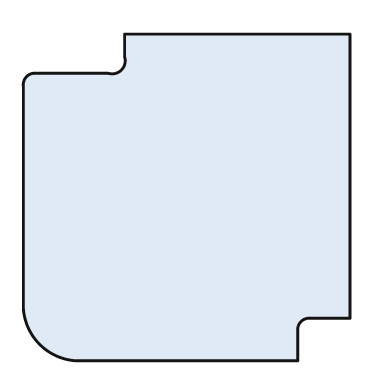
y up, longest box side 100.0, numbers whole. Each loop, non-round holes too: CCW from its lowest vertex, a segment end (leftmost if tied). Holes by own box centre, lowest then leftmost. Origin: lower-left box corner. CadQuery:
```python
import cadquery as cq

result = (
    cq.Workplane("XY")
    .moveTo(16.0, 0.0)
    .lineTo(84.0, 0.0)
    .lineTo(84.0, 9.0)
    .threePointArc((85.0, 12.0), (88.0, 13.0))
    .lineTo(100.0, 13.0)
    .lineTo(100.0, 100.0)
    .lineTo(31.0, 100.0)
    .lineTo(31.0, 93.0)
    .threePointArc((30.0, 89.0), (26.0, 88.0))
    .lineTo(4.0, 88.0)
    .threePointArc((1.0, 87.0), (0.0, 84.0))
    .lineTo(0.0, 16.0)
    .threePointArc((5.0, 5.0), (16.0, 0.0))
    .close()
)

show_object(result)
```